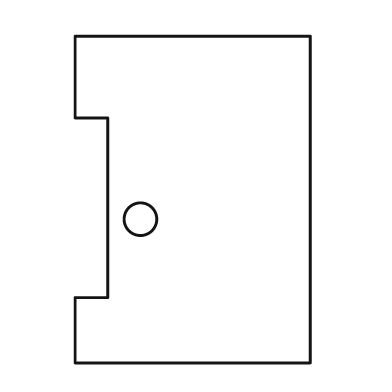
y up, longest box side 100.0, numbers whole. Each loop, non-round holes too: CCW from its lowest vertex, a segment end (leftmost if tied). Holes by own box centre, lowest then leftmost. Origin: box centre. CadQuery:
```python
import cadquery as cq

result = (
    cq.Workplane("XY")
    .moveTo(-36.0, -50.0)
    .lineTo(36.0, -50.0)
    .lineTo(36.0, 50.0)
    .lineTo(-36.0, 50.0)
    .lineTo(-36.0, 25.0)
    .lineTo(-26.0, 25.0)
    .lineTo(-26.0, -30.0)
    .lineTo(-36.0, -30.0)
    .close()
    .moveTo(-16.0, -6.0)
    .circle(5.0)
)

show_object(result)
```